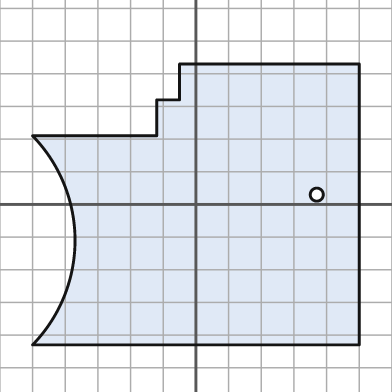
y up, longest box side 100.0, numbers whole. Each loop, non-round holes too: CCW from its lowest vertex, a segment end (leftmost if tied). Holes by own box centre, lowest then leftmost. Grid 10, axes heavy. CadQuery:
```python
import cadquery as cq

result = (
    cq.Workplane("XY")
    .moveTo(-50.0, -43.0)
    .lineTo(50.0, -43.0)
    .lineTo(50.0, 43.0)
    .lineTo(-5.0, 43.0)
    .lineTo(-5.0, 32.0)
    .lineTo(-12.0, 32.0)
    .lineTo(-12.0, 21.0)
    .lineTo(-50.0, 21.0)
    .threePointArc((-37.0, -11.0), (-50.0, -43.0))
    .close()
    .moveTo(37.0, 3.0)
    .circle(2.0)
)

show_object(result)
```